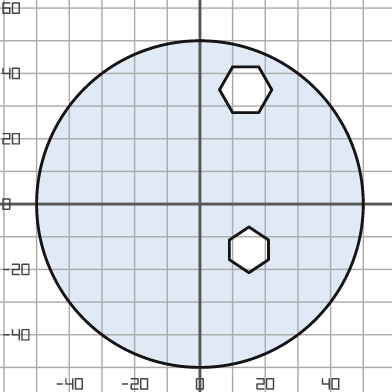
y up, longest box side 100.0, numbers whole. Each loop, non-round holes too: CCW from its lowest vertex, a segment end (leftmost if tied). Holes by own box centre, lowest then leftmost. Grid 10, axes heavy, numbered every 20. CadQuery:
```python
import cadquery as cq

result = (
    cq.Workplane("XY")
    .moveTo(0.0, 0.0)
    .circle(50.0)
    .moveTo(15.0, -21.0)
    .lineTo(21.0, -17.0)
    .lineTo(21.0, -11.0)
    .lineTo(15.0, -7.0)
    .lineTo(9.0, -11.0)
    .lineTo(9.0, -17.0)
    .close()
    .moveTo(10.0, 28.0)
    .lineTo(18.0, 28.0)
    .lineTo(22.0, 35.0)
    .lineTo(18.0, 42.0)
    .lineTo(10.0, 42.0)
    .lineTo(6.0, 35.0)
    .close()
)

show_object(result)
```